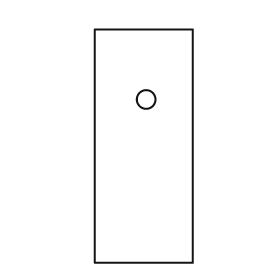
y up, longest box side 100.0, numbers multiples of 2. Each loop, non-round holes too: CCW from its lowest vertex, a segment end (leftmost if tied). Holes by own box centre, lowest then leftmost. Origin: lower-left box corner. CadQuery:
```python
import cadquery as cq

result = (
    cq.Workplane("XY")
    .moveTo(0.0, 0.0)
    .lineTo(42.0, 0.0)
    .lineTo(42.0, 100.0)
    .lineTo(0.0, 100.0)
    .close()
    .moveTo(22.0, 70.0)
    .circle(4.0)
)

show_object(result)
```